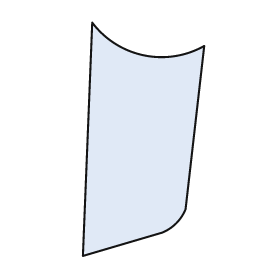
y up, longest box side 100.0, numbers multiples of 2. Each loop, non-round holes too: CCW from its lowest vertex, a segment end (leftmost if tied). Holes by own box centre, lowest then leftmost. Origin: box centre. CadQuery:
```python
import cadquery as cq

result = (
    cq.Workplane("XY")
    .moveTo(-26.0, -50.0)
    .lineTo(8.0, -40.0)
    .threePointArc((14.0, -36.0), (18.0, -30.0))
    .lineTo(26.0, 40.0)
    .threePointArc((0.0, 36.0), (-22.0, 50.0))
    .close()
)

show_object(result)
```